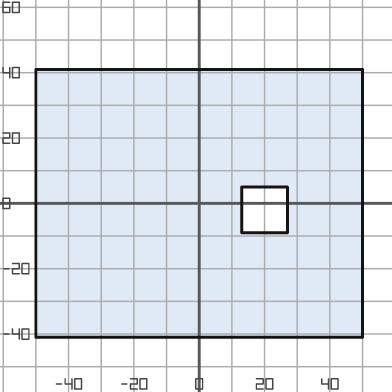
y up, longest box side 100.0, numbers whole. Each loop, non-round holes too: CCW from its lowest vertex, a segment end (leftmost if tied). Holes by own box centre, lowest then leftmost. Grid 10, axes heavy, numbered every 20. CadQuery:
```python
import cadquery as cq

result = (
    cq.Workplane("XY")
    .moveTo(-50.0, -41.0)
    .lineTo(50.0, -41.0)
    .lineTo(50.0, 41.0)
    .lineTo(-50.0, 41.0)
    .close()
    .moveTo(13.0, -9.0)
    .lineTo(27.0, -9.0)
    .lineTo(27.0, 5.0)
    .lineTo(13.0, 5.0)
    .close()
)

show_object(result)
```